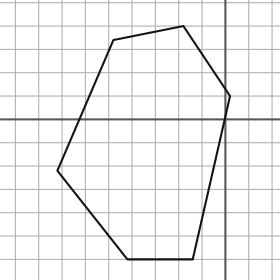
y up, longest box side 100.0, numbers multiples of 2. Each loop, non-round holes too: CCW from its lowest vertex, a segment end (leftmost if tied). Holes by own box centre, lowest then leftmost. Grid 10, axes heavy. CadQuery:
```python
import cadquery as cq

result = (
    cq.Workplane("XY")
    .moveTo(-42.0, -60.0)
    .lineTo(-14.0, -60.0)
    .lineTo(2.0, 10.0)
    .lineTo(-18.0, 40.0)
    .lineTo(-48.0, 34.0)
    .lineTo(-72.0, -22.0)
    .close()
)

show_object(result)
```